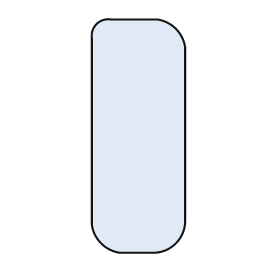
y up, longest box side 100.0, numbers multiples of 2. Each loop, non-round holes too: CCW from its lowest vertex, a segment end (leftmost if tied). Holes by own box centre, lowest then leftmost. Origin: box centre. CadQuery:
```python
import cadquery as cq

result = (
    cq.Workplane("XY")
    .moveTo(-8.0, -50.0)
    .lineTo(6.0, -50.0)
    .threePointArc((16.0, -46.0), (20.0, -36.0))
    .lineTo(20.0, 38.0)
    .threePointArc((16.0, 46.0), (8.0, 50.0))
    .lineTo(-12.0, 50.0)
    .threePointArc((-18.0, 48.0), (-20.0, 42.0))
    .lineTo(-20.0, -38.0)
    .threePointArc((-16.0, -46.0), (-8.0, -50.0))
    .close()
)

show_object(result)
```